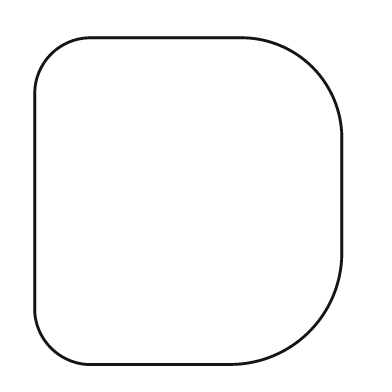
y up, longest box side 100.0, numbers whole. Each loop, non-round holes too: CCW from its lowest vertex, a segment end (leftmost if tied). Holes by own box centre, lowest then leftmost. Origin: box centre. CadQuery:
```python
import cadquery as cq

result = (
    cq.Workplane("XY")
    .moveTo(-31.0, -50.0)
    .lineTo(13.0, -50.0)
    .threePointArc((37.0, -40.0), (47.0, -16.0))
    .lineTo(47.0, 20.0)
    .threePointArc((38.0, 41.0), (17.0, 50.0))
    .lineTo(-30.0, 50.0)
    .threePointArc((-42.0, 45.0), (-47.0, 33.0))
    .lineTo(-47.0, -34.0)
    .threePointArc((-42.0, -45.0), (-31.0, -50.0))
    .close()
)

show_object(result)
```